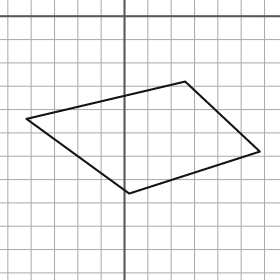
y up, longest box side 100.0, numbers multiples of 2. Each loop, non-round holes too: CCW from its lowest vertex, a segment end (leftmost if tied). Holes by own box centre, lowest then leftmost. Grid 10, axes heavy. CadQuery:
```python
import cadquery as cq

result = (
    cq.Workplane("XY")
    .moveTo(2.0, -76.0)
    .lineTo(58.0, -58.0)
    .lineTo(26.0, -28.0)
    .lineTo(-42.0, -44.0)
    .close()
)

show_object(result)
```